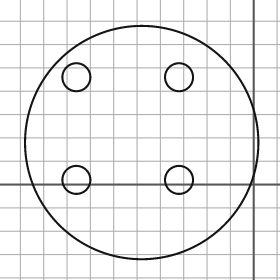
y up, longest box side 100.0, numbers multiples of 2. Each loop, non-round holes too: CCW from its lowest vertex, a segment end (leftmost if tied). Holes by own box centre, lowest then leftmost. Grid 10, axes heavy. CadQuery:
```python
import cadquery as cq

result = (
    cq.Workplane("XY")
    .moveTo(-48.0, 18.0)
    .circle(50.0)
    .moveTo(-76.0, 2.0)
    .circle(6.0)
    .moveTo(-32.0, 2.0)
    .circle(6.0)
    .moveTo(-76.0, 46.0)
    .circle(6.0)
    .moveTo(-32.0, 46.0)
    .circle(6.0)
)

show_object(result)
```